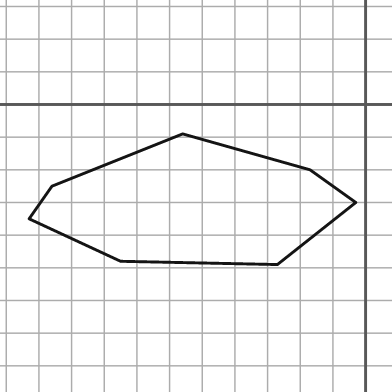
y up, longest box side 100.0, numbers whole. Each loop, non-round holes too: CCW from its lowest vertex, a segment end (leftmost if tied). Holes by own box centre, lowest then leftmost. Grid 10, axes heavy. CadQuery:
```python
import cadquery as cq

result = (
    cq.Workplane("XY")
    .moveTo(-27.0, -49.0)
    .lineTo(-3.0, -30.0)
    .lineTo(-17.0, -20.0)
    .lineTo(-56.0, -9.0)
    .lineTo(-96.0, -25.0)
    .lineTo(-103.0, -35.0)
    .lineTo(-75.0, -48.0)
    .close()
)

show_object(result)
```